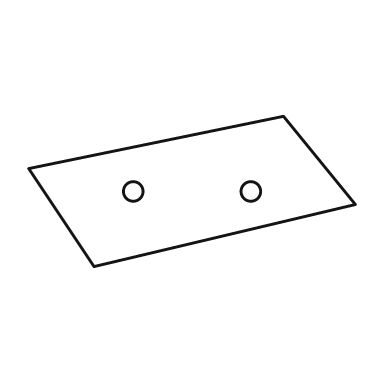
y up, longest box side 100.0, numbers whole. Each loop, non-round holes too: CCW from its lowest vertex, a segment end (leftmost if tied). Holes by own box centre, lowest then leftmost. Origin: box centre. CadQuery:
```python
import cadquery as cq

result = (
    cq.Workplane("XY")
    .moveTo(-30.0, -23.0)
    .lineTo(50.0, -4.0)
    .lineTo(28.0, 23.0)
    .lineTo(-50.0, 7.0)
    .close()
    .moveTo(-18.0, 0.0)
    .circle(3.0)
    .moveTo(18.0, 0.0)
    .circle(3.0)
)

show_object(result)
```